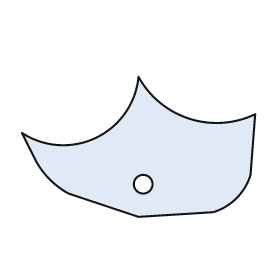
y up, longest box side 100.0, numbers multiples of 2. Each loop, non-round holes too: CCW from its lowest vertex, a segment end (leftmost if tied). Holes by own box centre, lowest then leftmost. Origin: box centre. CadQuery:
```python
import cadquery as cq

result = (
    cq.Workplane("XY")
    .moveTo(0.0, -30.0)
    .lineTo(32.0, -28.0)
    .threePointArc((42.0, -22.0), (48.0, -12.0))
    .lineTo(50.0, 14.0)
    .threePointArc((22.0, 12.0), (0.0, 30.0))
    .threePointArc((-18.0, 4.0), (-50.0, 6.0))
    .lineTo(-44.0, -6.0)
    .threePointArc((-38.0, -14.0), (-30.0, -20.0))
    .close()
    .moveTo(2.0, -16.0)
    .circle(4.0)
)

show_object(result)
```